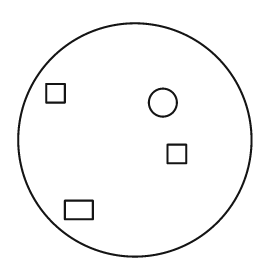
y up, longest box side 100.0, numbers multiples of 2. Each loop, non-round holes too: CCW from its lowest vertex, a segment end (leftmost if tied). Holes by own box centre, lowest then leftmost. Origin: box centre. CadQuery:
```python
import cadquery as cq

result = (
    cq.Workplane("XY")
    .moveTo(0.0, 0.0)
    .circle(50.0)
    .moveTo(-30.0, -34.0)
    .lineTo(-18.0, -34.0)
    .lineTo(-18.0, -26.0)
    .lineTo(-30.0, -26.0)
    .close()
    .moveTo(14.0, -10.0)
    .lineTo(22.0, -10.0)
    .lineTo(22.0, -2.0)
    .lineTo(14.0, -2.0)
    .close()
    .moveTo(12.0, 16.0)
    .circle(6.0)
    .moveTo(-38.0, 16.0)
    .lineTo(-30.0, 16.0)
    .lineTo(-30.0, 24.0)
    .lineTo(-38.0, 24.0)
    .close()
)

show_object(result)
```